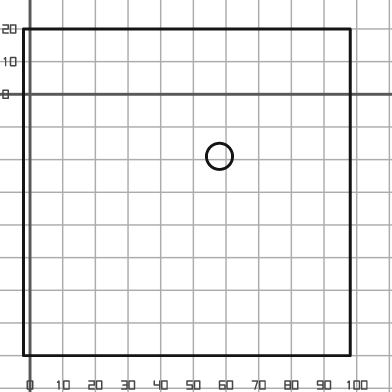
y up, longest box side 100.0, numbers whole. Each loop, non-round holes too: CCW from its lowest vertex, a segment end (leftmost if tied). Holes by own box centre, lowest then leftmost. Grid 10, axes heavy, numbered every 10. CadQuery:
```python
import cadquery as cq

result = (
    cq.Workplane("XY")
    .moveTo(-2.0, -80.0)
    .lineTo(98.0, -80.0)
    .lineTo(98.0, 20.0)
    .lineTo(-2.0, 20.0)
    .close()
    .moveTo(58.0, -19.0)
    .circle(4.0)
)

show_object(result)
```